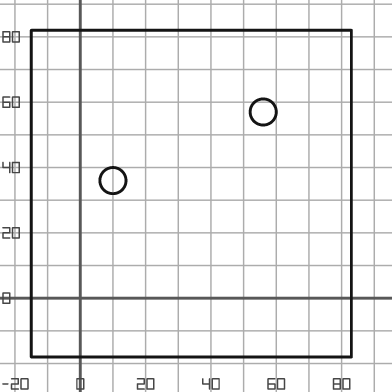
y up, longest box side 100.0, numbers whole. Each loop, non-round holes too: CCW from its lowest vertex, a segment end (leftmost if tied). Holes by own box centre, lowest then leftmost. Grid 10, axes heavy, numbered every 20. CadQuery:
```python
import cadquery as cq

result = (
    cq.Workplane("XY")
    .moveTo(-15.0, -18.0)
    .lineTo(83.0, -18.0)
    .lineTo(83.0, 82.0)
    .lineTo(-15.0, 82.0)
    .close()
    .moveTo(10.0, 36.0)
    .circle(4.0)
    .moveTo(56.0, 57.0)
    .circle(4.0)
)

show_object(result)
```